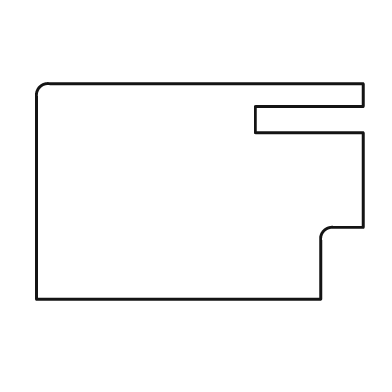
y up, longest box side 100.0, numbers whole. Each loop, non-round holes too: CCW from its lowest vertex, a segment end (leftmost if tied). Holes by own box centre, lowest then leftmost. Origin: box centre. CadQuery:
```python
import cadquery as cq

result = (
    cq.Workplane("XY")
    .moveTo(-50.0, -33.0)
    .lineTo(37.0, -33.0)
    .lineTo(37.0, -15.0)
    .threePointArc((38.0, -12.0), (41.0, -11.0))
    .lineTo(50.0, -11.0)
    .lineTo(50.0, 18.0)
    .lineTo(17.0, 18.0)
    .lineTo(17.0, 26.0)
    .lineTo(50.0, 26.0)
    .lineTo(50.0, 33.0)
    .lineTo(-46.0, 33.0)
    .threePointArc((-49.0, 32.0), (-50.0, 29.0))
    .close()
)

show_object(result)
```